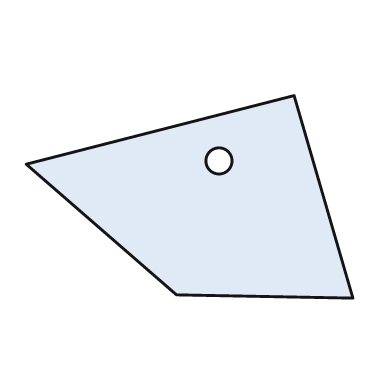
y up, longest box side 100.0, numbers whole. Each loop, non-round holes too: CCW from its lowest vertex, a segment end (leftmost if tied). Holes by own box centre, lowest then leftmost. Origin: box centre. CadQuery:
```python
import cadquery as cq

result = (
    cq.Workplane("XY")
    .moveTo(50.0, -31.0)
    .lineTo(32.0, 31.0)
    .lineTo(-50.0, 10.0)
    .lineTo(-4.0, -30.0)
    .close()
    .moveTo(9.0, 11.0)
    .circle(4.0)
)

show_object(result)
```